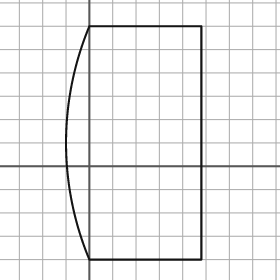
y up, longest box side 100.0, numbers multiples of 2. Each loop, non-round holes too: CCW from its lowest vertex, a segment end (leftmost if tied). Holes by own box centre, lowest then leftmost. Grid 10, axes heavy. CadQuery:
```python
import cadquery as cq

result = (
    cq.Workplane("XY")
    .moveTo(0.0, -40.0)
    .lineTo(48.0, -40.0)
    .lineTo(48.0, 60.0)
    .lineTo(0.0, 60.0)
    .threePointArc((-10.0, 10.0), (0.0, -40.0))
    .close()
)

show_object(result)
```